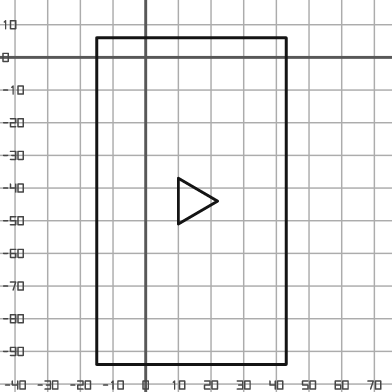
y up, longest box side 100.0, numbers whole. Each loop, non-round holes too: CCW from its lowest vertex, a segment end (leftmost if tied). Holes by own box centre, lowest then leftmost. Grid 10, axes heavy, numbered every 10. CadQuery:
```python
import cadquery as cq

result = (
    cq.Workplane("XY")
    .moveTo(-15.0, -94.0)
    .lineTo(43.0, -94.0)
    .lineTo(43.0, 6.0)
    .lineTo(-15.0, 6.0)
    .close()
    .moveTo(10.0, -51.0)
    .lineTo(22.0, -44.0)
    .lineTo(10.0, -37.0)
    .close()
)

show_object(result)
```